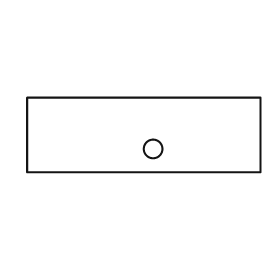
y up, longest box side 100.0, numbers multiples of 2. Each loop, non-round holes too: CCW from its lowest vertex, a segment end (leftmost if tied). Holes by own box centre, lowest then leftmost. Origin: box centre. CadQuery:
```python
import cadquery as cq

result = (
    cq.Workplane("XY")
    .moveTo(-50.0, -16.0)
    .lineTo(50.0, -16.0)
    .lineTo(50.0, 16.0)
    .lineTo(-50.0, 16.0)
    .close()
    .moveTo(4.0, -6.0)
    .circle(4.0)
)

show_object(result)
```